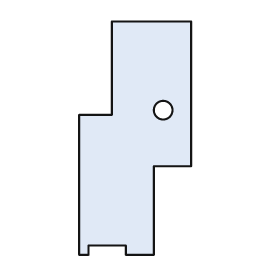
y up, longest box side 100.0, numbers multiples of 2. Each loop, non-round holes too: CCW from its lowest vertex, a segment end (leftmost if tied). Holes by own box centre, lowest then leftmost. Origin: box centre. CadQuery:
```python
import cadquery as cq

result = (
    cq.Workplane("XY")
    .moveTo(-24.0, -50.0)
    .lineTo(-20.0, -50.0)
    .lineTo(-20.0, -46.0)
    .lineTo(-4.0, -46.0)
    .lineTo(-4.0, -50.0)
    .lineTo(8.0, -50.0)
    .lineTo(8.0, -12.0)
    .lineTo(24.0, -12.0)
    .lineTo(24.0, 50.0)
    .lineTo(-10.0, 50.0)
    .lineTo(-10.0, 10.0)
    .lineTo(-24.0, 10.0)
    .close()
    .moveTo(12.0, 12.0)
    .circle(4.0)
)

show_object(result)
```